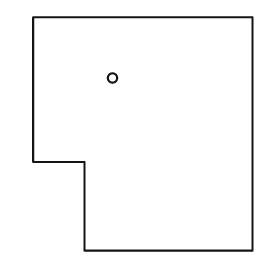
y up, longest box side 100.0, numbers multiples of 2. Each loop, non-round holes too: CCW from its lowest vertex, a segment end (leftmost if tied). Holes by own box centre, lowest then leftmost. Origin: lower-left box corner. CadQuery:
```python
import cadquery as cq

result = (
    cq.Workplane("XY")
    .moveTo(22.0, 0.0)
    .lineTo(94.0, 0.0)
    .lineTo(94.0, 100.0)
    .lineTo(0.0, 100.0)
    .lineTo(0.0, 38.0)
    .lineTo(22.0, 38.0)
    .close()
    .moveTo(34.0, 74.0)
    .circle(2.0)
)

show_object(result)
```